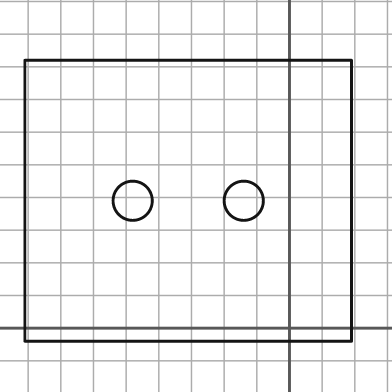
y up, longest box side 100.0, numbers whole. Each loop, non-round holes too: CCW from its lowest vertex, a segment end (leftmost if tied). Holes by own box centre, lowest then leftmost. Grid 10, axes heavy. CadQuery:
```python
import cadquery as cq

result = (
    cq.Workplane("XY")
    .moveTo(-81.0, -4.0)
    .lineTo(19.0, -4.0)
    .lineTo(19.0, 82.0)
    .lineTo(-81.0, 82.0)
    .close()
    .moveTo(-48.0, 39.0)
    .circle(6.0)
    .moveTo(-14.0, 39.0)
    .circle(6.0)
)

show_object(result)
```